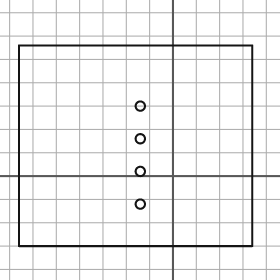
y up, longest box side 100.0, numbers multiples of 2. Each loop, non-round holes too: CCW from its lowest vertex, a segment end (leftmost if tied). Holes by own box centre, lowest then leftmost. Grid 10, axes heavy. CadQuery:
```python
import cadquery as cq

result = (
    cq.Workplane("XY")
    .moveTo(-66.0, -30.0)
    .lineTo(34.0, -30.0)
    .lineTo(34.0, 56.0)
    .lineTo(-66.0, 56.0)
    .close()
    .moveTo(-14.0, -12.0)
    .circle(2.0)
    .moveTo(-14.0, 2.0)
    .circle(2.0)
    .moveTo(-14.0, 16.0)
    .circle(2.0)
    .moveTo(-14.0, 30.0)
    .circle(2.0)
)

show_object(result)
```